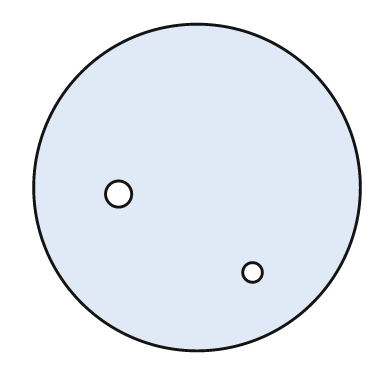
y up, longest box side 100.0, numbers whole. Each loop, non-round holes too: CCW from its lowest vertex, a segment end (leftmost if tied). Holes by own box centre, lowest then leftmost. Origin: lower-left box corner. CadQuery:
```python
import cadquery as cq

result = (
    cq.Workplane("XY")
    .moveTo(50.0, 50.0)
    .circle(50.0)
    .moveTo(67.0, 24.0)
    .circle(3.0)
    .moveTo(26.0, 48.0)
    .circle(4.0)
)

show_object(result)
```